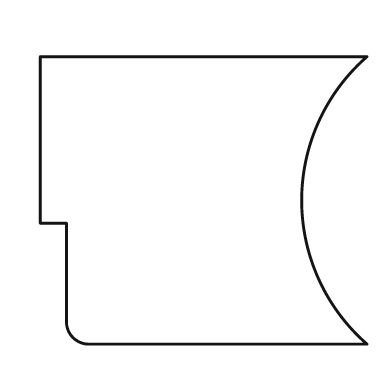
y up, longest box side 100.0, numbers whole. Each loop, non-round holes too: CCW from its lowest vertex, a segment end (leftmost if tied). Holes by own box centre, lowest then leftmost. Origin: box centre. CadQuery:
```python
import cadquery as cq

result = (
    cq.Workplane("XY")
    .moveTo(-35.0, -44.0)
    .lineTo(50.0, -44.0)
    .threePointArc((30.0, 0.0), (50.0, 44.0))
    .lineTo(-50.0, 44.0)
    .lineTo(-50.0, -7.0)
    .lineTo(-42.0, -7.0)
    .lineTo(-42.0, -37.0)
    .threePointArc((-40.0, -42.0), (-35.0, -44.0))
    .close()
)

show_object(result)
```